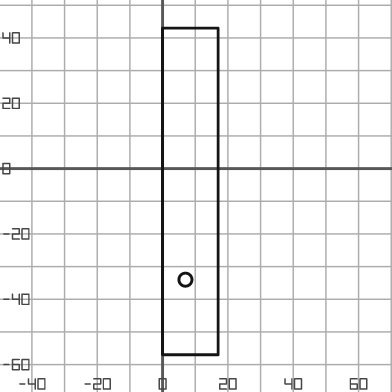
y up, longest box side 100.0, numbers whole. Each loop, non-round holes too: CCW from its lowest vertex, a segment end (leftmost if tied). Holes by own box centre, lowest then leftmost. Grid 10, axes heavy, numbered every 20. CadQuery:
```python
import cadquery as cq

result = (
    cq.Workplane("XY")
    .moveTo(0.0, -57.0)
    .lineTo(17.0, -57.0)
    .lineTo(17.0, 43.0)
    .lineTo(0.0, 43.0)
    .close()
    .moveTo(7.0, -34.0)
    .circle(2.0)
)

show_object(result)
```